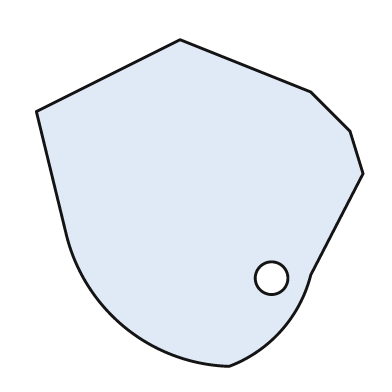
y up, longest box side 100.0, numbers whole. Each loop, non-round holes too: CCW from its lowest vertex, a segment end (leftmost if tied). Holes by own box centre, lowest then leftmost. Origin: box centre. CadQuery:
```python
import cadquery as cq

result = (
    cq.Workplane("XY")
    .moveTo(9.0, -50.0)
    .threePointArc((25.0, -39.0), (34.0, -22.0))
    .lineTo(50.0, 9.0)
    .lineTo(46.0, 22.0)
    .lineTo(34.0, 34.0)
    .lineTo(-6.0, 50.0)
    .lineTo(-50.0, 28.0)
    .lineTo(-41.0, -9.0)
    .threePointArc((-23.0, -38.0), (9.0, -50.0))
    .close()
    .moveTo(22.0, -23.0)
    .circle(5.0)
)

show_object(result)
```